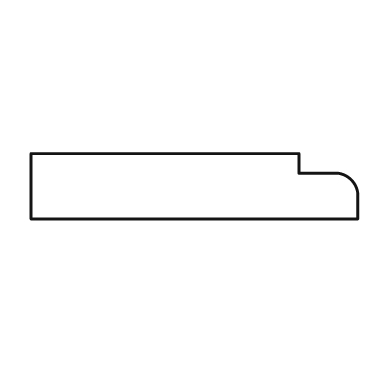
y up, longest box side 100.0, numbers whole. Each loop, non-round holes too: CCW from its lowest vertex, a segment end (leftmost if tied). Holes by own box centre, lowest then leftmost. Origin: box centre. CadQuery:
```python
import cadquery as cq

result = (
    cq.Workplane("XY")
    .moveTo(-50.0, -10.0)
    .lineTo(50.0, -10.0)
    .lineTo(50.0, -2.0)
    .threePointArc((48.0, 2.0), (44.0, 4.0))
    .lineTo(32.0, 4.0)
    .lineTo(32.0, 10.0)
    .lineTo(-50.0, 10.0)
    .close()
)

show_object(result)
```